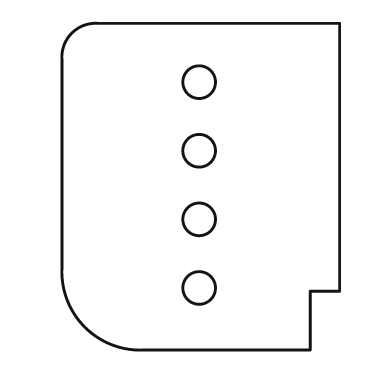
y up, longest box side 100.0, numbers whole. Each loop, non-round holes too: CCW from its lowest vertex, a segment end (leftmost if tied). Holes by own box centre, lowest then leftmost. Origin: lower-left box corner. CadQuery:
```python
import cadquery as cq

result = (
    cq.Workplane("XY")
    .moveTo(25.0, 0.0)
    .lineTo(76.0, 0.0)
    .lineTo(76.0, 18.0)
    .lineTo(85.0, 18.0)
    .lineTo(85.0, 100.0)
    .lineTo(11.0, 100.0)
    .threePointArc((3.0, 97.0), (0.0, 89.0))
    .lineTo(0.0, 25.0)
    .threePointArc((7.0, 7.0), (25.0, 0.0))
    .close()
    .moveTo(42.0, 19.0)
    .circle(5.0)
    .moveTo(42.0, 40.0)
    .circle(5.0)
    .moveTo(42.0, 61.0)
    .circle(5.0)
    .moveTo(42.0, 82.0)
    .circle(5.0)
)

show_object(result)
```